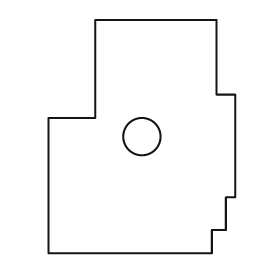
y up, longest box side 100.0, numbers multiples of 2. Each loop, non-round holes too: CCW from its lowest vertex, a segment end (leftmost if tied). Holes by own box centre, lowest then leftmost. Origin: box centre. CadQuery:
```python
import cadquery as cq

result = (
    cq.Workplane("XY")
    .moveTo(-40.0, -50.0)
    .lineTo(30.0, -50.0)
    .lineTo(30.0, -40.0)
    .lineTo(36.0, -40.0)
    .lineTo(36.0, -26.0)
    .lineTo(40.0, -26.0)
    .lineTo(40.0, 18.0)
    .lineTo(32.0, 18.0)
    .lineTo(32.0, 50.0)
    .lineTo(-20.0, 50.0)
    .lineTo(-20.0, 8.0)
    .lineTo(-40.0, 8.0)
    .close()
    .moveTo(0.0, 0.0)
    .circle(8.0)
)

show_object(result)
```